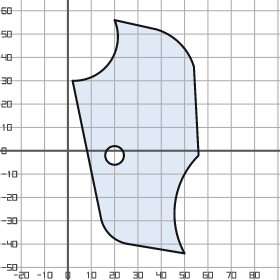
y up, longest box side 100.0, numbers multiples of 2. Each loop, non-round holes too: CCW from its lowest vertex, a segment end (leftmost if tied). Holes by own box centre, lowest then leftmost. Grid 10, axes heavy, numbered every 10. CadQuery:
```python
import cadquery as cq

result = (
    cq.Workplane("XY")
    .moveTo(50.0, -44.0)
    .threePointArc((46.0, -22.0), (56.0, -2.0))
    .lineTo(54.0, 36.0)
    .threePointArc((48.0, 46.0), (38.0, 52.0))
    .lineTo(20.0, 56.0)
    .threePointArc((18.0, 38.0), (2.0, 30.0))
    .lineTo(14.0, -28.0)
    .threePointArc((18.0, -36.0), (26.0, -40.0))
    .close()
    .moveTo(20.0, -2.0)
    .circle(4.0)
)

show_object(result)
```